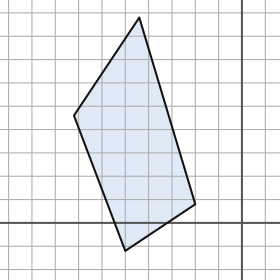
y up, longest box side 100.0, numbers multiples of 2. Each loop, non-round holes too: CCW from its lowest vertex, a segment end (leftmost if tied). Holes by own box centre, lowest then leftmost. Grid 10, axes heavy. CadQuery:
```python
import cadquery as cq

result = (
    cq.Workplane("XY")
    .moveTo(-50.0, -12.0)
    .lineTo(-20.0, 8.0)
    .lineTo(-44.0, 88.0)
    .lineTo(-72.0, 46.0)
    .close()
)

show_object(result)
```